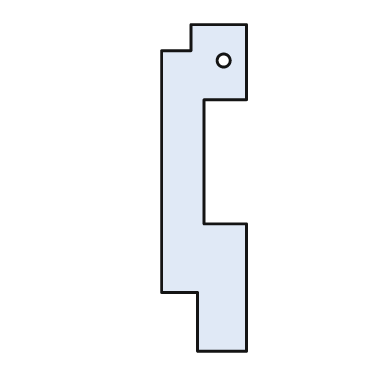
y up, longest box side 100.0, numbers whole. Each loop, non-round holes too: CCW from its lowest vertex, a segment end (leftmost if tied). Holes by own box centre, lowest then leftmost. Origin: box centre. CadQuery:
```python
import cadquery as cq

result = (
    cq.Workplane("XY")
    .moveTo(-2.0, -50.0)
    .lineTo(13.0, -50.0)
    .lineTo(13.0, -11.0)
    .lineTo(0.0, -11.0)
    .lineTo(0.0, 27.0)
    .lineTo(13.0, 27.0)
    .lineTo(13.0, 50.0)
    .lineTo(-4.0, 50.0)
    .lineTo(-4.0, 42.0)
    .lineTo(-13.0, 42.0)
    .lineTo(-13.0, -32.0)
    .lineTo(-2.0, -32.0)
    .close()
    .moveTo(6.0, 39.0)
    .circle(2.0)
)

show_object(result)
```